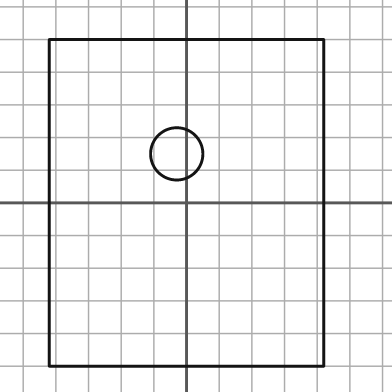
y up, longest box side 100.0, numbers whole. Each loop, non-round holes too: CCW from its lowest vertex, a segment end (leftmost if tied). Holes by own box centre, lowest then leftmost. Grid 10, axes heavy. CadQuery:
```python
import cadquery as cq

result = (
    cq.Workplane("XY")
    .moveTo(-42.0, -50.0)
    .lineTo(42.0, -50.0)
    .lineTo(42.0, 50.0)
    .lineTo(-42.0, 50.0)
    .close()
    .moveTo(-3.0, 15.0)
    .circle(8.0)
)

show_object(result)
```